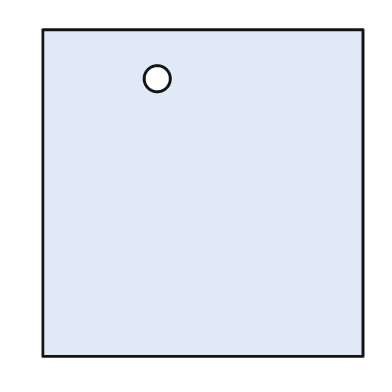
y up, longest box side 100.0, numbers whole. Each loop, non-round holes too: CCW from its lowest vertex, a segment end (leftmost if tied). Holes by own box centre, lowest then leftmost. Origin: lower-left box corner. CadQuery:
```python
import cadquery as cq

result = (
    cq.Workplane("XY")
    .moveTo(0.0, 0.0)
    .lineTo(98.0, 0.0)
    .lineTo(98.0, 100.0)
    .lineTo(0.0, 100.0)
    .close()
    .moveTo(35.0, 85.0)
    .circle(4.0)
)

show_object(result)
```